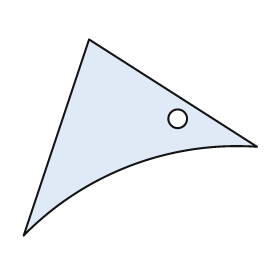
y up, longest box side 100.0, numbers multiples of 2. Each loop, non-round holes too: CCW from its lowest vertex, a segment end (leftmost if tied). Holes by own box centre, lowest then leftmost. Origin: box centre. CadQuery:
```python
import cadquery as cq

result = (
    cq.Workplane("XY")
    .moveTo(-50.0, -42.0)
    .threePointArc((-4.0, -12.0), (50.0, -4.0))
    .lineTo(-22.0, 42.0)
    .close()
    .moveTo(16.0, 8.0)
    .circle(4.0)
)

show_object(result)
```